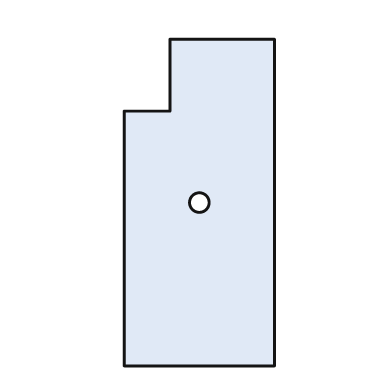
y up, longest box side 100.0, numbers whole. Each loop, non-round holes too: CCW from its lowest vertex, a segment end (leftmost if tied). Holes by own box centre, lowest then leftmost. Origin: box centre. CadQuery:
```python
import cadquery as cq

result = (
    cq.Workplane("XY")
    .moveTo(-23.0, -50.0)
    .lineTo(23.0, -50.0)
    .lineTo(23.0, 50.0)
    .lineTo(-9.0, 50.0)
    .lineTo(-9.0, 28.0)
    .lineTo(-23.0, 28.0)
    .close()
    .moveTo(0.0, 0.0)
    .circle(3.0)
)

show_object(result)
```